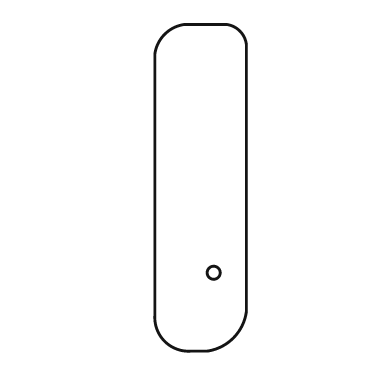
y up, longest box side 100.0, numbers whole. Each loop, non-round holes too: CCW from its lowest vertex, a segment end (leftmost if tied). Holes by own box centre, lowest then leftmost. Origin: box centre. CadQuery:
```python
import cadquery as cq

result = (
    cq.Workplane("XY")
    .moveTo(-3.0, -50.0)
    .lineTo(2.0, -50.0)
    .threePointArc((10.0, -46.0), (14.0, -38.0))
    .lineTo(14.0, 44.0)
    .threePointArc((12.0, 48.0), (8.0, 50.0))
    .lineTo(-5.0, 50.0)
    .threePointArc((-11.0, 47.0), (-14.0, 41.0))
    .lineTo(-14.0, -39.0)
    .threePointArc((-11.0, -47.0), (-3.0, -50.0))
    .close()
    .moveTo(4.0, -26.0)
    .circle(2.0)
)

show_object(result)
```